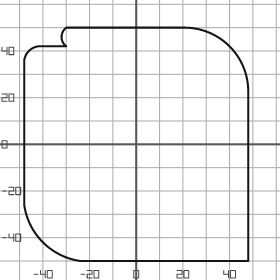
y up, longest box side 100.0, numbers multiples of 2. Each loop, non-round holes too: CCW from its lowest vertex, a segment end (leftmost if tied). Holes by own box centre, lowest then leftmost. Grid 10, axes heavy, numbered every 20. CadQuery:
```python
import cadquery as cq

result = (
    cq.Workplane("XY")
    .moveTo(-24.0, -50.0)
    .lineTo(48.0, -50.0)
    .lineTo(48.0, 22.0)
    .threePointArc((40.0, 42.0), (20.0, 50.0))
    .lineTo(-30.0, 50.0)
    .threePointArc((-32.0, 46.0), (-30.0, 42.0))
    .lineTo(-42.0, 42.0)
    .threePointArc((-46.0, 40.0), (-48.0, 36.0))
    .lineTo(-48.0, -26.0)
    .threePointArc((-40.0, -42.0), (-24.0, -50.0))
    .close()
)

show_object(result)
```